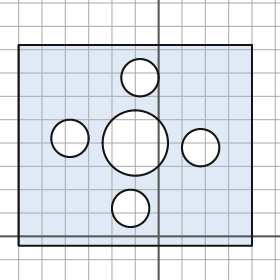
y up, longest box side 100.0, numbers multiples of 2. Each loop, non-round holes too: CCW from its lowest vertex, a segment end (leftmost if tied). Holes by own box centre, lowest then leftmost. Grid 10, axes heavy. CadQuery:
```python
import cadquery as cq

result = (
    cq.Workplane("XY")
    .moveTo(-60.0, -4.0)
    .lineTo(40.0, -4.0)
    .lineTo(40.0, 82.0)
    .lineTo(-60.0, 82.0)
    .close()
    .moveTo(-12.0, 12.0)
    .circle(8.0)
    .moveTo(18.0, 38.0)
    .circle(8.0)
    .moveTo(-10.0, 40.0)
    .circle(14.0)
    .moveTo(-38.0, 42.0)
    .circle(8.0)
    .moveTo(-8.0, 68.0)
    .circle(8.0)
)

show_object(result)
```